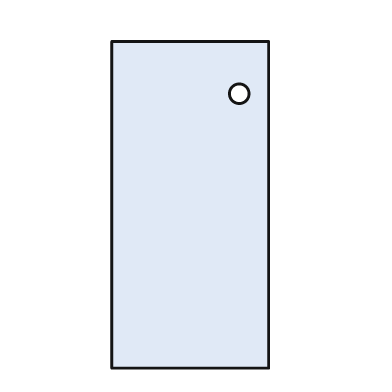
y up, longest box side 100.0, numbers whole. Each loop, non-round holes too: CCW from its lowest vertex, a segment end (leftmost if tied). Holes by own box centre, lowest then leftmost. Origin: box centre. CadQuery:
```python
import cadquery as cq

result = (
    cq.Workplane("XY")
    .moveTo(-24.0, -50.0)
    .lineTo(24.0, -50.0)
    .lineTo(24.0, 50.0)
    .lineTo(-24.0, 50.0)
    .close()
    .moveTo(15.0, 34.0)
    .circle(3.0)
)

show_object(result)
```